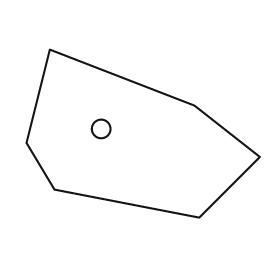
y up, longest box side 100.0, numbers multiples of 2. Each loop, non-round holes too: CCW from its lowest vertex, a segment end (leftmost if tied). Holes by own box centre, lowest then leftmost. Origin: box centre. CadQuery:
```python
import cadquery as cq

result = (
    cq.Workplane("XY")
    .moveTo(24.0, -36.0)
    .lineTo(50.0, -10.0)
    .lineTo(22.0, 12.0)
    .lineTo(-40.0, 36.0)
    .lineTo(-50.0, -4.0)
    .lineTo(-38.0, -24.0)
    .close()
    .moveTo(-18.0, 2.0)
    .circle(4.0)
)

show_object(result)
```